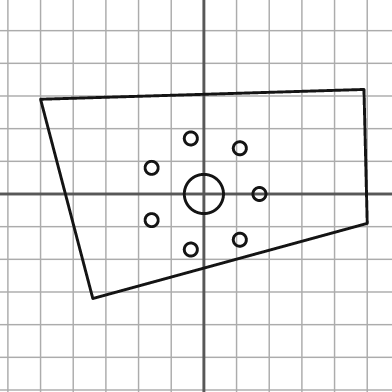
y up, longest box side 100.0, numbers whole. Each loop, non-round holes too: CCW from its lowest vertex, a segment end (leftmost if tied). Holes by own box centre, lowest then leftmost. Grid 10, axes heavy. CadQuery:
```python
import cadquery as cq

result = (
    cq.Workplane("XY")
    .moveTo(-34.0, -32.0)
    .lineTo(50.0, -9.0)
    .lineTo(49.0, 32.0)
    .lineTo(-50.0, 29.0)
    .close()
    .moveTo(-4.0, -17.0)
    .circle(2.0)
    .moveTo(11.0, -14.0)
    .circle(2.0)
    .moveTo(-16.0, -8.0)
    .circle(2.0)
    .moveTo(0.0, 0.0)
    .circle(6.0)
    .moveTo(17.0, 0.0)
    .circle(2.0)
    .moveTo(-16.0, 8.0)
    .circle(2.0)
    .moveTo(11.0, 14.0)
    .circle(2.0)
    .moveTo(-4.0, 17.0)
    .circle(2.0)
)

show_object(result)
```